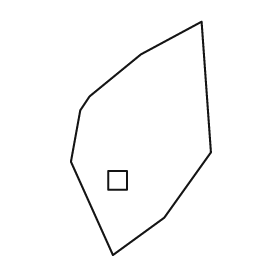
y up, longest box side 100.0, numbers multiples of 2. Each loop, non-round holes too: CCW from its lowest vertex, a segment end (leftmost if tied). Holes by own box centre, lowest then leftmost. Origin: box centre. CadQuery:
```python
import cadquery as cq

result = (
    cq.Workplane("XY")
    .moveTo(-12.0, -50.0)
    .lineTo(10.0, -34.0)
    .lineTo(30.0, -6.0)
    .lineTo(26.0, 50.0)
    .lineTo(0.0, 36.0)
    .lineTo(-22.0, 18.0)
    .lineTo(-26.0, 12.0)
    .lineTo(-30.0, -10.0)
    .close()
    .moveTo(-14.0, -22.0)
    .lineTo(-6.0, -22.0)
    .lineTo(-6.0, -14.0)
    .lineTo(-14.0, -14.0)
    .close()
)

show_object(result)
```